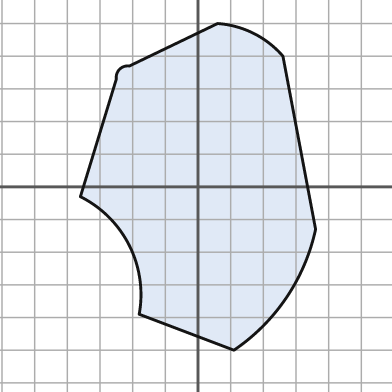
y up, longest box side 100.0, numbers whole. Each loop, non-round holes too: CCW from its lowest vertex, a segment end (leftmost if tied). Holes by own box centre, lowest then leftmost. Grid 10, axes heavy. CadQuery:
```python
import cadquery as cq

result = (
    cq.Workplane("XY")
    .moveTo(11.0, -50.0)
    .threePointArc((27.0, -34.0), (36.0, -13.0))
    .lineTo(26.0, 40.0)
    .threePointArc((17.0, 47.0), (6.0, 50.0))
    .lineTo(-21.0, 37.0)
    .threePointArc((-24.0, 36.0), (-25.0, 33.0))
    .lineTo(-36.0, -3.0)
    .threePointArc((-21.0, -18.0), (-18.0, -39.0))
    .close()
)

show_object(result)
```